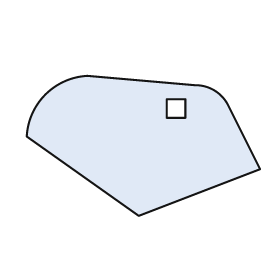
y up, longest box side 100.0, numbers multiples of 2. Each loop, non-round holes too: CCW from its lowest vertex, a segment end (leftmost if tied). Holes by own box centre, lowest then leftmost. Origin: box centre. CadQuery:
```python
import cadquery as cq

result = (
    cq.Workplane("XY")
    .moveTo(-2.0, -30.0)
    .lineTo(50.0, -10.0)
    .lineTo(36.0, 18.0)
    .threePointArc((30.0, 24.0), (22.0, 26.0))
    .lineTo(-24.0, 30.0)
    .threePointArc((-42.0, 22.0), (-50.0, 4.0))
    .close()
    .moveTo(10.0, 12.0)
    .lineTo(18.0, 12.0)
    .lineTo(18.0, 20.0)
    .lineTo(10.0, 20.0)
    .close()
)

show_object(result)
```